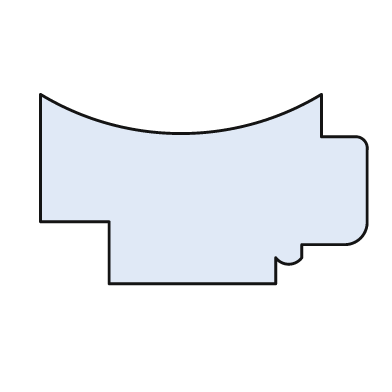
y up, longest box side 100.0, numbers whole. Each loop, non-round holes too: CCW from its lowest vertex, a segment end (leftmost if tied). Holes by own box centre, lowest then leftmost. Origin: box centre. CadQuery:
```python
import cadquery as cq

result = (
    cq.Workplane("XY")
    .moveTo(-29.0, -29.0)
    .lineTo(22.0, -29.0)
    .lineTo(22.0, -21.0)
    .threePointArc((26.0, -23.0), (30.0, -21.0))
    .lineTo(30.0, -17.0)
    .lineTo(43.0, -17.0)
    .threePointArc((48.0, -15.0), (50.0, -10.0))
    .lineTo(50.0, 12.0)
    .threePointArc((49.0, 15.0), (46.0, 16.0))
    .lineTo(36.0, 16.0)
    .lineTo(36.0, 29.0)
    .threePointArc((-7.0, 17.0), (-50.0, 29.0))
    .lineTo(-50.0, -10.0)
    .lineTo(-29.0, -10.0)
    .close()
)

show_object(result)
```